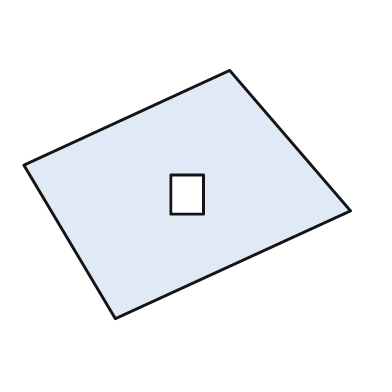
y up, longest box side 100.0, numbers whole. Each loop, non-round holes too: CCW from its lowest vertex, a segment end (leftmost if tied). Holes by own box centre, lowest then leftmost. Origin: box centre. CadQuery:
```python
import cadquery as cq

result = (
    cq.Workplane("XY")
    .moveTo(-22.0, -38.0)
    .lineTo(50.0, -5.0)
    .lineTo(13.0, 38.0)
    .lineTo(-50.0, 9.0)
    .close()
    .moveTo(-5.0, -6.0)
    .lineTo(5.0, -6.0)
    .lineTo(5.0, 6.0)
    .lineTo(-5.0, 6.0)
    .close()
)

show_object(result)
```